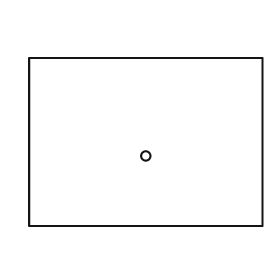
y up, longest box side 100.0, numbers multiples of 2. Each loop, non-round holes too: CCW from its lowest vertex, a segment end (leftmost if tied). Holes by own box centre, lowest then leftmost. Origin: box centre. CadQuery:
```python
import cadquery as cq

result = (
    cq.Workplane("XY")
    .moveTo(-50.0, -36.0)
    .lineTo(50.0, -36.0)
    .lineTo(50.0, 36.0)
    .lineTo(-50.0, 36.0)
    .close()
    .moveTo(0.0, -6.0)
    .circle(2.0)
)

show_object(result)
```